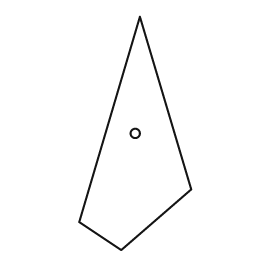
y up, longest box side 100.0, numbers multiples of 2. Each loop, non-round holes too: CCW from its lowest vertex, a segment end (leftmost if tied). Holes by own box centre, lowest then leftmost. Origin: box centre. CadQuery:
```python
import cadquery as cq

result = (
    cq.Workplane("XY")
    .moveTo(-6.0, -50.0)
    .lineTo(24.0, -24.0)
    .lineTo(2.0, 50.0)
    .lineTo(-24.0, -38.0)
    .close()
    .moveTo(0.0, 0.0)
    .circle(2.0)
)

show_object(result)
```